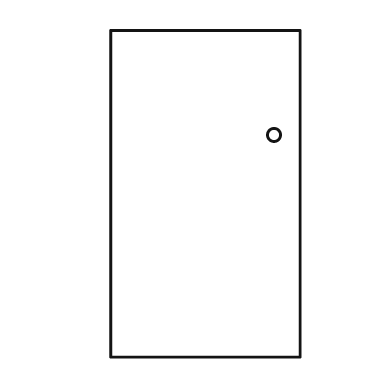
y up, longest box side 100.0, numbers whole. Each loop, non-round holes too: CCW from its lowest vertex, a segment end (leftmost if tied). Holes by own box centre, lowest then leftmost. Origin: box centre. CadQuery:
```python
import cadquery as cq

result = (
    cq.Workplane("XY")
    .moveTo(-29.0, -50.0)
    .lineTo(29.0, -50.0)
    .lineTo(29.0, 50.0)
    .lineTo(-29.0, 50.0)
    .close()
    .moveTo(21.0, 18.0)
    .circle(2.0)
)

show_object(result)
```